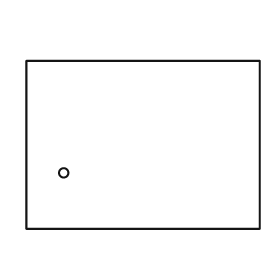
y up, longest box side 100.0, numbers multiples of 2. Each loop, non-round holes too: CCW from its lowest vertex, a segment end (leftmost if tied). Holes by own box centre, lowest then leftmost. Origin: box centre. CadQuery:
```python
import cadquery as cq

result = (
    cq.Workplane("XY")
    .moveTo(-50.0, -36.0)
    .lineTo(50.0, -36.0)
    .lineTo(50.0, 36.0)
    .lineTo(-50.0, 36.0)
    .close()
    .moveTo(-34.0, -12.0)
    .circle(2.0)
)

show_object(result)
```